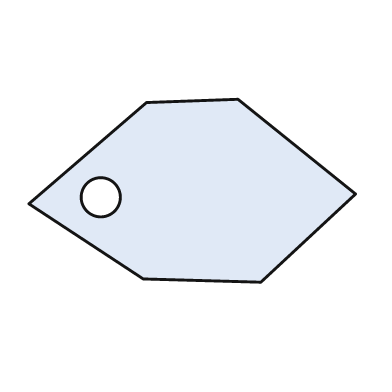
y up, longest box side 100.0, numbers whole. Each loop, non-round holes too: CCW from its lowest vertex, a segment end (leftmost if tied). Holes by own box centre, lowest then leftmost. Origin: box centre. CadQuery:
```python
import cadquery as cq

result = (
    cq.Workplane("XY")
    .moveTo(21.0, -28.0)
    .lineTo(50.0, -1.0)
    .lineTo(14.0, 28.0)
    .lineTo(-14.0, 27.0)
    .lineTo(-50.0, -4.0)
    .lineTo(-15.0, -27.0)
    .close()
    .moveTo(-28.0, -2.0)
    .circle(6.0)
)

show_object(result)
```